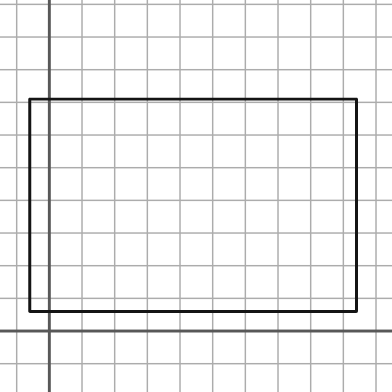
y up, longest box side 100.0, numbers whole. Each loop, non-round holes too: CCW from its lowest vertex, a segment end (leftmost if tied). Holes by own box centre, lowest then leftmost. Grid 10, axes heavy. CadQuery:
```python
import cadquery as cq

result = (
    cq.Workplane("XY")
    .moveTo(-6.0, 6.0)
    .lineTo(94.0, 6.0)
    .lineTo(94.0, 71.0)
    .lineTo(-6.0, 71.0)
    .close()
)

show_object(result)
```